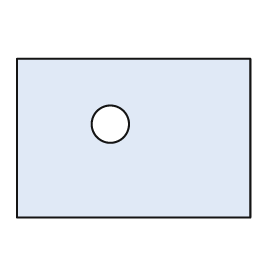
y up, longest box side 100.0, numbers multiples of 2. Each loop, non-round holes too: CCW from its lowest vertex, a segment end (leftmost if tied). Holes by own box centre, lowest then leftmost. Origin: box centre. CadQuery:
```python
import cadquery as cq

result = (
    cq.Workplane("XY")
    .moveTo(-50.0, -34.0)
    .lineTo(50.0, -34.0)
    .lineTo(50.0, 34.0)
    .lineTo(-50.0, 34.0)
    .close()
    .moveTo(-10.0, 6.0)
    .circle(8.0)
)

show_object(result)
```